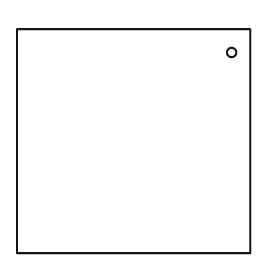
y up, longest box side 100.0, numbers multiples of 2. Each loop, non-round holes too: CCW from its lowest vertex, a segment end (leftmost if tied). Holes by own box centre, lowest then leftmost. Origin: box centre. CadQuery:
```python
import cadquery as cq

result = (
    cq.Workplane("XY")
    .moveTo(-50.0, -48.0)
    .lineTo(50.0, -48.0)
    .lineTo(50.0, 48.0)
    .lineTo(-50.0, 48.0)
    .close()
    .moveTo(42.0, 38.0)
    .circle(2.0)
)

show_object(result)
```